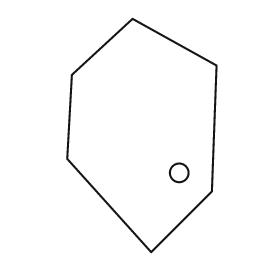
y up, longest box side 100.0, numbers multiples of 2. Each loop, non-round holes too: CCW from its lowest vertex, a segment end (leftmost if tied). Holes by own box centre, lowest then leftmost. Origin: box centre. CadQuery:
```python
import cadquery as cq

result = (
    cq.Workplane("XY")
    .moveTo(4.0, -50.0)
    .lineTo(30.0, -24.0)
    .lineTo(32.0, 30.0)
    .lineTo(-4.0, 50.0)
    .lineTo(-30.0, 26.0)
    .lineTo(-32.0, -10.0)
    .close()
    .moveTo(16.0, -16.0)
    .circle(4.0)
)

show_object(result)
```